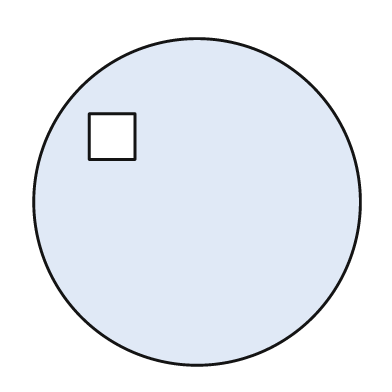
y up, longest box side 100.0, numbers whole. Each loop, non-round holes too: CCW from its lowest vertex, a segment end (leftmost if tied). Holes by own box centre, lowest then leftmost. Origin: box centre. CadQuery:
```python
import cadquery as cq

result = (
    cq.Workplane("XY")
    .moveTo(0.0, 0.0)
    .circle(50.0)
    .moveTo(-33.0, 13.0)
    .lineTo(-19.0, 13.0)
    .lineTo(-19.0, 27.0)
    .lineTo(-33.0, 27.0)
    .close()
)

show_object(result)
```